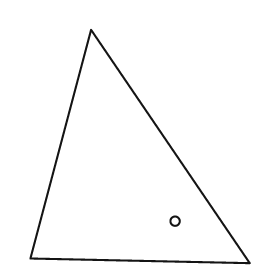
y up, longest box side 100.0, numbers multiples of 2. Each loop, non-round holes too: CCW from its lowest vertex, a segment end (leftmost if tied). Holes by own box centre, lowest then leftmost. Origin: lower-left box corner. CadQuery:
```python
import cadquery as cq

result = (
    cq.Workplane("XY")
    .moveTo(94.0, 0.0)
    .lineTo(26.0, 100.0)
    .lineTo(0.0, 2.0)
    .close()
    .moveTo(62.0, 18.0)
    .circle(2.0)
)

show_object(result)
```